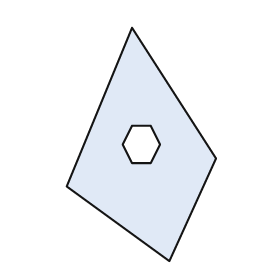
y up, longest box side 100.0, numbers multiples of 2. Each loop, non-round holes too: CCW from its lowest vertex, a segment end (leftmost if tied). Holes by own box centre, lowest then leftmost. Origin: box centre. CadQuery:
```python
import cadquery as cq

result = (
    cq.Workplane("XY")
    .moveTo(12.0, -50.0)
    .lineTo(32.0, -6.0)
    .lineTo(-4.0, 50.0)
    .lineTo(-32.0, -18.0)
    .close()
    .moveTo(-4.0, -8.0)
    .lineTo(4.0, -8.0)
    .lineTo(8.0, 0.0)
    .lineTo(4.0, 8.0)
    .lineTo(-4.0, 8.0)
    .lineTo(-8.0, 0.0)
    .close()
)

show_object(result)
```